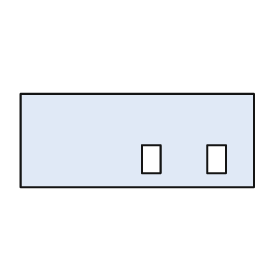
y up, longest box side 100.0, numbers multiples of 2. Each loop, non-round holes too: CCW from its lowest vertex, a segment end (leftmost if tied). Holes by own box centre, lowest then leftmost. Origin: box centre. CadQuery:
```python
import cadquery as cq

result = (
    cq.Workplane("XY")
    .moveTo(-50.0, -20.0)
    .lineTo(50.0, -20.0)
    .lineTo(50.0, 20.0)
    .lineTo(-50.0, 20.0)
    .close()
    .moveTo(2.0, -14.0)
    .lineTo(10.0, -14.0)
    .lineTo(10.0, -2.0)
    .lineTo(2.0, -2.0)
    .close()
    .moveTo(30.0, -14.0)
    .lineTo(38.0, -14.0)
    .lineTo(38.0, -2.0)
    .lineTo(30.0, -2.0)
    .close()
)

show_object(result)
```